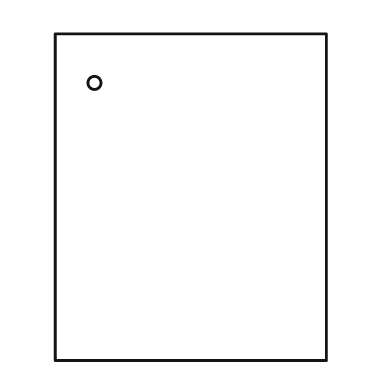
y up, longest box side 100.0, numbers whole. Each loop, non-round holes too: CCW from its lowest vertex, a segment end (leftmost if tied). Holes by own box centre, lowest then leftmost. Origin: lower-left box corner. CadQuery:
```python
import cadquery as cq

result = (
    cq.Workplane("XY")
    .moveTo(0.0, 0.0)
    .lineTo(83.0, 0.0)
    .lineTo(83.0, 100.0)
    .lineTo(0.0, 100.0)
    .close()
    .moveTo(12.0, 85.0)
    .circle(2.0)
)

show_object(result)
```